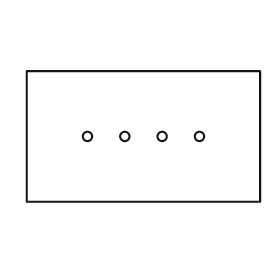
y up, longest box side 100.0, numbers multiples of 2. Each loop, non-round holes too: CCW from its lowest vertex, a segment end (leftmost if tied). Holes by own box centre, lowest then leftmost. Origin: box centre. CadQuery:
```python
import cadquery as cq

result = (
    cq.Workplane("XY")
    .moveTo(-50.0, -28.0)
    .lineTo(50.0, -28.0)
    .lineTo(50.0, 28.0)
    .lineTo(-50.0, 28.0)
    .close()
    .moveTo(-24.0, 0.0)
    .circle(2.0)
    .moveTo(-8.0, 0.0)
    .circle(2.0)
    .moveTo(8.0, 0.0)
    .circle(2.0)
    .moveTo(24.0, 0.0)
    .circle(2.0)
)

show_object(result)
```